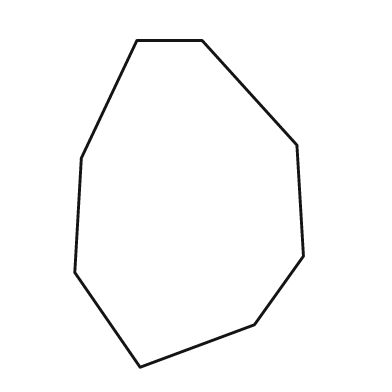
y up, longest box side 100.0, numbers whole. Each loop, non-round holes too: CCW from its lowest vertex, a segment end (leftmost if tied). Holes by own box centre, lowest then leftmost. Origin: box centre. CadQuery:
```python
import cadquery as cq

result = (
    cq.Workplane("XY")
    .moveTo(-15.0, -50.0)
    .lineTo(20.0, -37.0)
    .lineTo(35.0, -16.0)
    .lineTo(33.0, 18.0)
    .lineTo(4.0, 50.0)
    .lineTo(-16.0, 50.0)
    .lineTo(-33.0, 14.0)
    .lineTo(-35.0, -21.0)
    .close()
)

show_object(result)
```